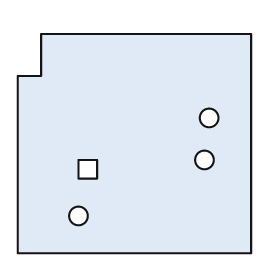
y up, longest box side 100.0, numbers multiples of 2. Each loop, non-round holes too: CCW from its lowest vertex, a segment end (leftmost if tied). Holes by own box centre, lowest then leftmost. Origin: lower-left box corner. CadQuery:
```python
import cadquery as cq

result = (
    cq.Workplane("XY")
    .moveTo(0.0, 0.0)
    .lineTo(100.0, 0.0)
    .lineTo(100.0, 94.0)
    .lineTo(10.0, 94.0)
    .lineTo(10.0, 76.0)
    .lineTo(0.0, 76.0)
    .close()
    .moveTo(26.0, 16.0)
    .circle(4.0)
    .moveTo(26.0, 32.0)
    .lineTo(34.0, 32.0)
    .lineTo(34.0, 40.0)
    .lineTo(26.0, 40.0)
    .close()
    .moveTo(80.0, 40.0)
    .circle(4.0)
    .moveTo(82.0, 58.0)
    .circle(4.0)
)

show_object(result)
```